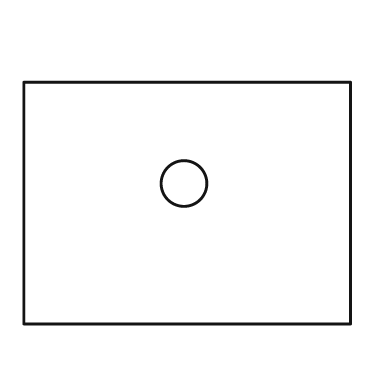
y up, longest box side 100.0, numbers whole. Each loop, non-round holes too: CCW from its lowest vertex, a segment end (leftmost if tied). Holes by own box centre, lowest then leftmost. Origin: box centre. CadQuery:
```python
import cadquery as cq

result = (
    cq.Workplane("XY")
    .moveTo(-50.0, -37.0)
    .lineTo(50.0, -37.0)
    .lineTo(50.0, 37.0)
    .lineTo(-50.0, 37.0)
    .close()
    .moveTo(-1.0, 6.0)
    .circle(7.0)
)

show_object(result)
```